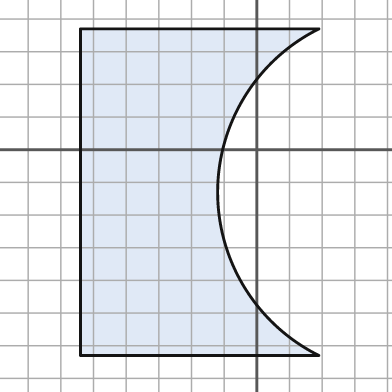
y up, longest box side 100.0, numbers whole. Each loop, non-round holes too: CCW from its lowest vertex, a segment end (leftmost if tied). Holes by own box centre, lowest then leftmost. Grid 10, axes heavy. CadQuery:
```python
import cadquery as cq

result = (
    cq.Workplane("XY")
    .moveTo(-54.0, -63.0)
    .lineTo(19.0, -63.0)
    .threePointArc((-12.0, -13.0), (19.0, 37.0))
    .lineTo(-54.0, 37.0)
    .close()
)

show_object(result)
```